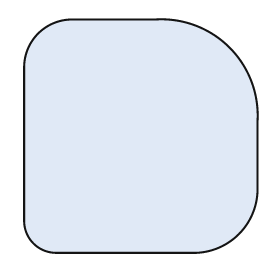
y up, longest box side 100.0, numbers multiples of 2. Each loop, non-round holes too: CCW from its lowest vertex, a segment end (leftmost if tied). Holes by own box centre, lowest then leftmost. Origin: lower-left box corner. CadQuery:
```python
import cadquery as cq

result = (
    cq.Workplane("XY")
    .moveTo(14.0, 0.0)
    .lineTo(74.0, 0.0)
    .threePointArc((92.0, 8.0), (100.0, 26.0))
    .lineTo(100.0, 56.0)
    .threePointArc((88.0, 88.0), (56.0, 100.0))
    .lineTo(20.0, 100.0)
    .threePointArc((6.0, 94.0), (0.0, 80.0))
    .lineTo(0.0, 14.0)
    .threePointArc((4.0, 4.0), (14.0, 0.0))
    .close()
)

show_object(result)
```